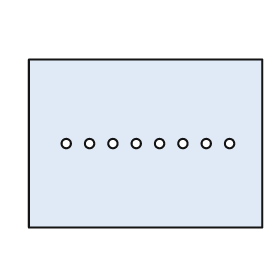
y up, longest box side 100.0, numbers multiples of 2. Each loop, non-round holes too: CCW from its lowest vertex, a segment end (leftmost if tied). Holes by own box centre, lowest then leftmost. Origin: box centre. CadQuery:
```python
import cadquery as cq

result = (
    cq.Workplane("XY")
    .moveTo(-50.0, -36.0)
    .lineTo(50.0, -36.0)
    .lineTo(50.0, 36.0)
    .lineTo(-50.0, 36.0)
    .close()
    .moveTo(-34.0, 0.0)
    .circle(2.0)
    .moveTo(-24.0, 0.0)
    .circle(2.0)
    .moveTo(-14.0, 0.0)
    .circle(2.0)
    .moveTo(-4.0, 0.0)
    .circle(2.0)
    .moveTo(6.0, 0.0)
    .circle(2.0)
    .moveTo(16.0, 0.0)
    .circle(2.0)
    .moveTo(26.0, 0.0)
    .circle(2.0)
    .moveTo(36.0, 0.0)
    .circle(2.0)
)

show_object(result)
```